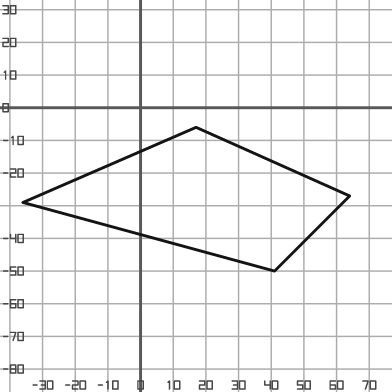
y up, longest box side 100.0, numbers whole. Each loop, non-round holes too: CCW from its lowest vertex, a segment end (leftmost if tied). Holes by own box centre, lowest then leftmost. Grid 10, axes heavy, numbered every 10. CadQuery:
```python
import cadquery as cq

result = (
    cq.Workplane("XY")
    .moveTo(41.0, -50.0)
    .lineTo(64.0, -27.0)
    .lineTo(17.0, -6.0)
    .lineTo(-36.0, -29.0)
    .close()
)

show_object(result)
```